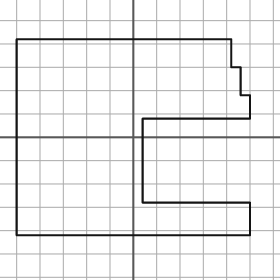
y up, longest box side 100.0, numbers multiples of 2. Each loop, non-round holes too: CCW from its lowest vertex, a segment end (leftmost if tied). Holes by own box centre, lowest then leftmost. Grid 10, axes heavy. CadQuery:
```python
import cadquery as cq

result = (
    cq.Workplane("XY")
    .moveTo(-50.0, -42.0)
    .lineTo(50.0, -42.0)
    .lineTo(50.0, -28.0)
    .lineTo(4.0, -28.0)
    .lineTo(4.0, 8.0)
    .lineTo(50.0, 8.0)
    .lineTo(50.0, 18.0)
    .lineTo(46.0, 18.0)
    .lineTo(46.0, 30.0)
    .lineTo(42.0, 30.0)
    .lineTo(42.0, 42.0)
    .lineTo(-50.0, 42.0)
    .close()
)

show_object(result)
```